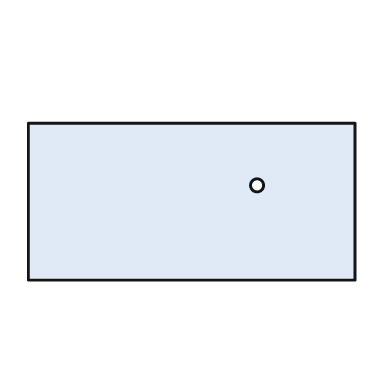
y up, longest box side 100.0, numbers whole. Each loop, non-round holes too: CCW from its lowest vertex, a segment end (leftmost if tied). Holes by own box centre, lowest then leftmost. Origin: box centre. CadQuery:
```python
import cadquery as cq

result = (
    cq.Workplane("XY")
    .moveTo(-50.0, -24.0)
    .lineTo(50.0, -24.0)
    .lineTo(50.0, 24.0)
    .lineTo(-50.0, 24.0)
    .close()
    .moveTo(20.0, 5.0)
    .circle(2.0)
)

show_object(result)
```